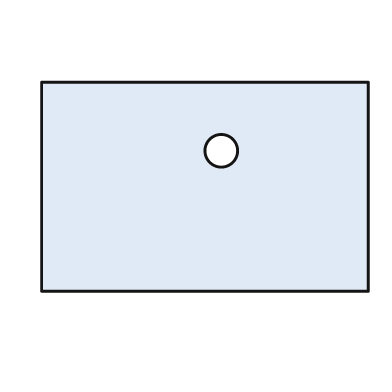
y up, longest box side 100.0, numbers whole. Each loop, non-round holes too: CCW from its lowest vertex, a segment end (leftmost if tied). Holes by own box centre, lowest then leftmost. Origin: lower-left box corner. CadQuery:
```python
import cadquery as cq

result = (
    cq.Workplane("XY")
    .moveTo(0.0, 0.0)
    .lineTo(100.0, 0.0)
    .lineTo(100.0, 64.0)
    .lineTo(0.0, 64.0)
    .close()
    .moveTo(55.0, 43.0)
    .circle(5.0)
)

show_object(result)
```